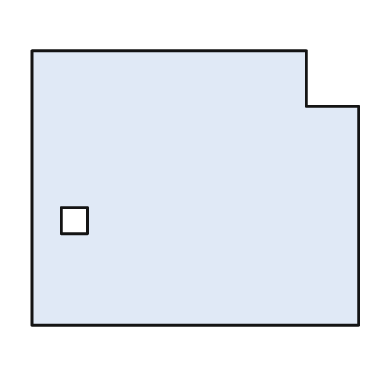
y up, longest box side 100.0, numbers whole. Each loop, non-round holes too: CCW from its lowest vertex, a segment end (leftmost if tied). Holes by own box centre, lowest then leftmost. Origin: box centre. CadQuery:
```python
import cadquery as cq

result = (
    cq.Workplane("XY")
    .moveTo(-50.0, -42.0)
    .lineTo(50.0, -42.0)
    .lineTo(50.0, 25.0)
    .lineTo(34.0, 25.0)
    .lineTo(34.0, 42.0)
    .lineTo(-50.0, 42.0)
    .close()
    .moveTo(-41.0, -14.0)
    .lineTo(-33.0, -14.0)
    .lineTo(-33.0, -6.0)
    .lineTo(-41.0, -6.0)
    .close()
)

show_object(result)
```